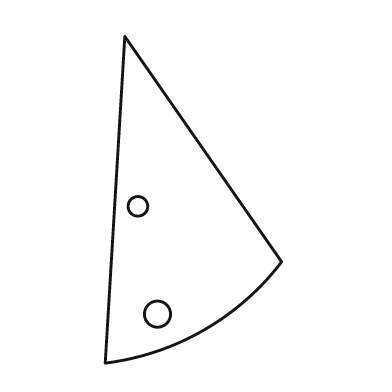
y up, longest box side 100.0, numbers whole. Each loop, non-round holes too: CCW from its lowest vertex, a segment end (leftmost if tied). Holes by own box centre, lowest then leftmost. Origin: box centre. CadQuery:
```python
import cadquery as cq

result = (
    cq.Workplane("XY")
    .moveTo(-27.0, -50.0)
    .threePointArc((3.0, -40.0), (27.0, -19.0))
    .lineTo(-21.0, 50.0)
    .close()
    .moveTo(-11.0, -35.0)
    .circle(4.0)
    .moveTo(-17.0, -2.0)
    .circle(3.0)
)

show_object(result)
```